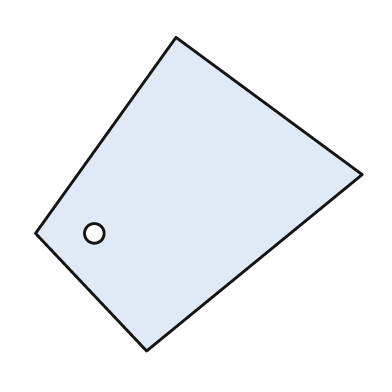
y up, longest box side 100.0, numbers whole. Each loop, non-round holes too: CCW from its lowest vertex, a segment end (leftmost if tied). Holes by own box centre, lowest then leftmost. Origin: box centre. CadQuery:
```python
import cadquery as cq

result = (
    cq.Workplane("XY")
    .moveTo(-16.0, -48.0)
    .lineTo(50.0, 6.0)
    .lineTo(-7.0, 48.0)
    .lineTo(-50.0, -12.0)
    .close()
    .moveTo(-32.0, -12.0)
    .circle(3.0)
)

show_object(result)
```